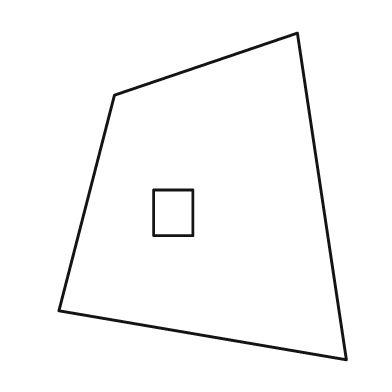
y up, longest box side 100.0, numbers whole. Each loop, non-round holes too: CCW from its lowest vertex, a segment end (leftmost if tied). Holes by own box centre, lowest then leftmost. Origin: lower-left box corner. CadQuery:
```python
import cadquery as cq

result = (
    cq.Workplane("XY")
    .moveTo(88.0, 0.0)
    .lineTo(73.0, 100.0)
    .lineTo(17.0, 81.0)
    .lineTo(0.0, 15.0)
    .close()
    .moveTo(29.0, 38.0)
    .lineTo(41.0, 38.0)
    .lineTo(41.0, 52.0)
    .lineTo(29.0, 52.0)
    .close()
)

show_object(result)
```